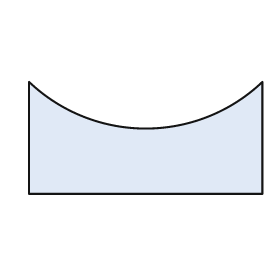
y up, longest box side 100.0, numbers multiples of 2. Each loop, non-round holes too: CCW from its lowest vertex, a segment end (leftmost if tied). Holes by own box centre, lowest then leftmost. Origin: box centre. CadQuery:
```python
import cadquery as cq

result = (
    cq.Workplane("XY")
    .moveTo(-50.0, -24.0)
    .lineTo(50.0, -24.0)
    .lineTo(50.0, 24.0)
    .threePointArc((0.0, 4.0), (-50.0, 24.0))
    .close()
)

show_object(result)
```